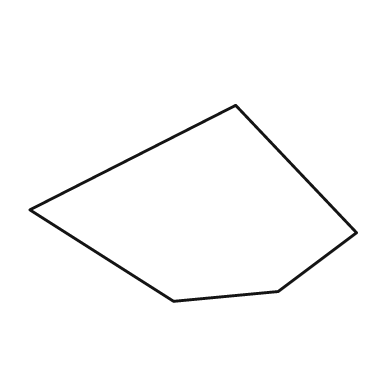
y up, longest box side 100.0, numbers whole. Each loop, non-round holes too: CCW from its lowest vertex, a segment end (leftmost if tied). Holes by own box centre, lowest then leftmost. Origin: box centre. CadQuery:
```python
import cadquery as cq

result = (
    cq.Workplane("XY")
    .moveTo(-6.0, -30.0)
    .lineTo(26.0, -27.0)
    .lineTo(50.0, -9.0)
    .lineTo(13.0, 30.0)
    .lineTo(-50.0, -2.0)
    .close()
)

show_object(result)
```